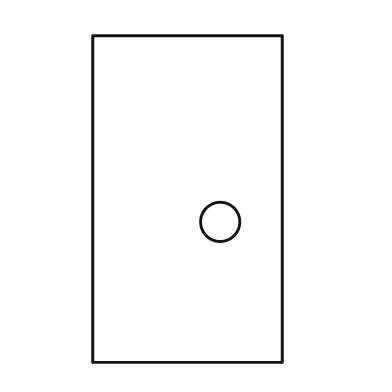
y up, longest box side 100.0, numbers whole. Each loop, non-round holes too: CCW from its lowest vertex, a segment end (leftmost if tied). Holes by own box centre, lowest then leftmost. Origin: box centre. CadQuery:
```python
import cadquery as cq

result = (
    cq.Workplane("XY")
    .moveTo(-29.0, -50.0)
    .lineTo(29.0, -50.0)
    .lineTo(29.0, 50.0)
    .lineTo(-29.0, 50.0)
    .close()
    .moveTo(10.0, -7.0)
    .circle(6.0)
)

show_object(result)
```